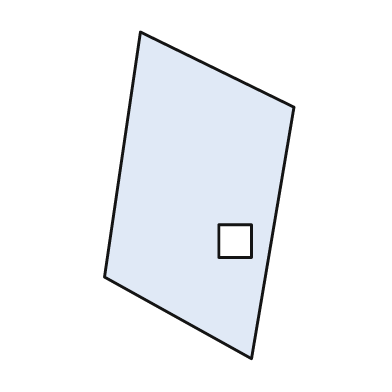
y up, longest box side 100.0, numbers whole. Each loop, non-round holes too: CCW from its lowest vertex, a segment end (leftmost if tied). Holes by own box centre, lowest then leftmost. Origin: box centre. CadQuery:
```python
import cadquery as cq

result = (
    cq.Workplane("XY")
    .moveTo(16.0, -50.0)
    .lineTo(29.0, 27.0)
    .lineTo(-18.0, 50.0)
    .lineTo(-29.0, -25.0)
    .close()
    .moveTo(6.0, -19.0)
    .lineTo(16.0, -19.0)
    .lineTo(16.0, -9.0)
    .lineTo(6.0, -9.0)
    .close()
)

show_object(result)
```